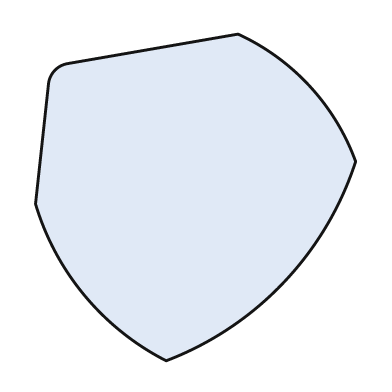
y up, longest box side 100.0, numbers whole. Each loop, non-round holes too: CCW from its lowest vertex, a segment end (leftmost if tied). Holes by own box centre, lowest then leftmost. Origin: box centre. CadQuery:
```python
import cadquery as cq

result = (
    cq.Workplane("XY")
    .moveTo(-9.0, -50.0)
    .threePointArc((27.0, -26.0), (49.0, 11.0))
    .threePointArc((35.0, 34.0), (13.0, 50.0))
    .lineTo(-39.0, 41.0)
    .threePointArc((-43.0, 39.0), (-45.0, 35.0))
    .lineTo(-49.0, -2.0)
    .threePointArc((-34.0, -30.0), (-9.0, -50.0))
    .close()
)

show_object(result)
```